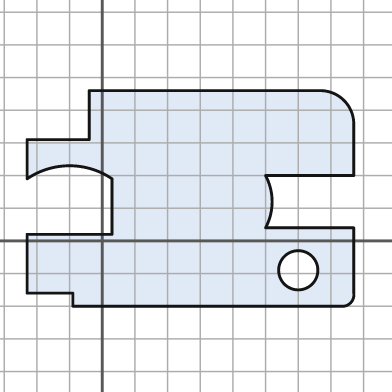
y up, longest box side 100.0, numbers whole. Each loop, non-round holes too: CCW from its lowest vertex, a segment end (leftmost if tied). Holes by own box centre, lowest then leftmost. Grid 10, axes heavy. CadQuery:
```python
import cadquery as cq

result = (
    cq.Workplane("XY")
    .moveTo(-9.0, -20.0)
    .lineTo(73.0, -20.0)
    .threePointArc((76.0, -19.0), (77.0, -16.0))
    .lineTo(77.0, 4.0)
    .lineTo(50.0, 4.0)
    .threePointArc((52.0, 12.0), (50.0, 20.0))
    .lineTo(77.0, 20.0)
    .lineTo(77.0, 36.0)
    .threePointArc((74.0, 43.0), (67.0, 46.0))
    .lineTo(-4.0, 46.0)
    .lineTo(-4.0, 31.0)
    .lineTo(-23.0, 31.0)
    .lineTo(-23.0, 19.0)
    .threePointArc((-10.0, 23.0), (3.0, 19.0))
    .lineTo(3.0, 2.0)
    .lineTo(-23.0, 2.0)
    .lineTo(-23.0, -16.0)
    .lineTo(-9.0, -16.0)
    .close()
    .moveTo(60.0, -9.0)
    .circle(6.0)
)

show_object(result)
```